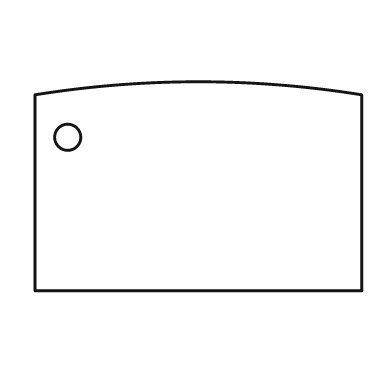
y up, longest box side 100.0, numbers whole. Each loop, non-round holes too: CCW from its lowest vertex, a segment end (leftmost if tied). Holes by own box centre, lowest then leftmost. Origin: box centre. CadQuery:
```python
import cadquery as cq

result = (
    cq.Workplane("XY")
    .moveTo(-50.0, -32.0)
    .lineTo(50.0, -32.0)
    .lineTo(50.0, 28.0)
    .threePointArc((0.0, 32.0), (-50.0, 28.0))
    .close()
    .moveTo(-40.0, 15.0)
    .circle(4.0)
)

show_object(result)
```